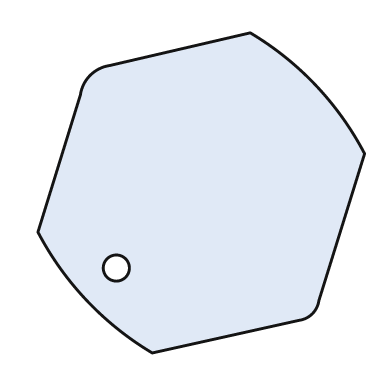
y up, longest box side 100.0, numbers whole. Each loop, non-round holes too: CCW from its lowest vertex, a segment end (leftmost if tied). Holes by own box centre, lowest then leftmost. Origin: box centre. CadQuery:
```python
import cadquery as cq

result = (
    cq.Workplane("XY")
    .moveTo(-15.0, -49.0)
    .lineTo(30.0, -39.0)
    .threePointArc((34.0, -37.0), (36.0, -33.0))
    .lineTo(50.0, 12.0)
    .threePointArc((35.0, 33.0), (15.0, 49.0))
    .lineTo(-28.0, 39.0)
    .threePointArc((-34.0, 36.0), (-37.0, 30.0))
    .lineTo(-50.0, -12.0)
    .threePointArc((-35.0, -33.0), (-15.0, -49.0))
    .close()
    .moveTo(-26.0, -23.0)
    .circle(4.0)
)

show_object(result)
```